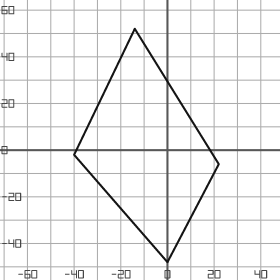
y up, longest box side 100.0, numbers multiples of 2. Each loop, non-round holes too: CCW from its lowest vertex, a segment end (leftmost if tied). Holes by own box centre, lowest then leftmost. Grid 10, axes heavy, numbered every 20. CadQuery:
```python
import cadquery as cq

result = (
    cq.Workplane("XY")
    .moveTo(0.0, -48.0)
    .lineTo(22.0, -6.0)
    .lineTo(-14.0, 52.0)
    .lineTo(-40.0, -2.0)
    .close()
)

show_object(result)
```